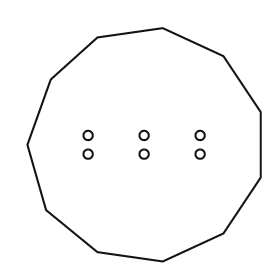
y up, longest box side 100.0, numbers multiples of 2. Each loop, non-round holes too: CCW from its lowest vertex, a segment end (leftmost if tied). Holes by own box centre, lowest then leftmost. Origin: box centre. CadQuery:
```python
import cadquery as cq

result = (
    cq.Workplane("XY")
    .moveTo(8.0, -50.0)
    .lineTo(34.0, -38.0)
    .lineTo(50.0, -14.0)
    .lineTo(50.0, 14.0)
    .lineTo(34.0, 38.0)
    .lineTo(8.0, 50.0)
    .lineTo(-20.0, 46.0)
    .lineTo(-40.0, 28.0)
    .lineTo(-50.0, 0.0)
    .lineTo(-42.0, -28.0)
    .lineTo(-20.0, -46.0)
    .close()
    .moveTo(-24.0, -4.0)
    .circle(2.0)
    .moveTo(0.0, -4.0)
    .circle(2.0)
    .moveTo(24.0, -4.0)
    .circle(2.0)
    .moveTo(-24.0, 4.0)
    .circle(2.0)
    .moveTo(0.0, 4.0)
    .circle(2.0)
    .moveTo(24.0, 4.0)
    .circle(2.0)
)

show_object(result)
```